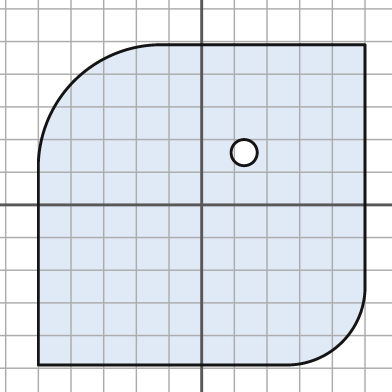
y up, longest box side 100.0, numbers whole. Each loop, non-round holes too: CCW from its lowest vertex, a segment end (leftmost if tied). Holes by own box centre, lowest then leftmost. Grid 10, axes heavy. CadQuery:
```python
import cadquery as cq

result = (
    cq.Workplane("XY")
    .moveTo(-50.0, -49.0)
    .lineTo(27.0, -49.0)
    .threePointArc((43.0, -42.0), (50.0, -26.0))
    .lineTo(50.0, 49.0)
    .lineTo(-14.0, 49.0)
    .threePointArc((-39.0, 38.0), (-50.0, 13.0))
    .close()
    .moveTo(13.0, 16.0)
    .circle(4.0)
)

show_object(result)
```